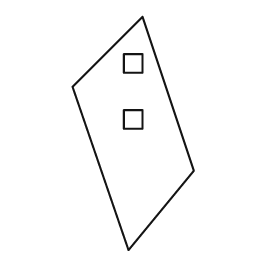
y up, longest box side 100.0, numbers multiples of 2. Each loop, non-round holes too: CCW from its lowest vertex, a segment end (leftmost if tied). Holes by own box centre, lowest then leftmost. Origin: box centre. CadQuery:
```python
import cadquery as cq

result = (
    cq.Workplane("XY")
    .moveTo(-2.0, -50.0)
    .lineTo(26.0, -16.0)
    .lineTo(4.0, 50.0)
    .lineTo(-26.0, 20.0)
    .close()
    .moveTo(-4.0, 2.0)
    .lineTo(4.0, 2.0)
    .lineTo(4.0, 10.0)
    .lineTo(-4.0, 10.0)
    .close()
    .moveTo(-4.0, 26.0)
    .lineTo(4.0, 26.0)
    .lineTo(4.0, 34.0)
    .lineTo(-4.0, 34.0)
    .close()
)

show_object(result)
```